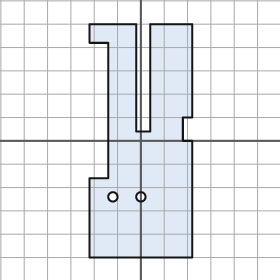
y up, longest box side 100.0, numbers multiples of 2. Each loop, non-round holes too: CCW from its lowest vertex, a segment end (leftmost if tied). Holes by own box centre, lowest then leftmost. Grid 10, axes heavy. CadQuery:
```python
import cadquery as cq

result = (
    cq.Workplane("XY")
    .moveTo(-22.0, -50.0)
    .lineTo(22.0, -50.0)
    .lineTo(22.0, 0.0)
    .lineTo(18.0, 0.0)
    .lineTo(18.0, 10.0)
    .lineTo(22.0, 10.0)
    .lineTo(22.0, 50.0)
    .lineTo(4.0, 50.0)
    .lineTo(4.0, 4.0)
    .lineTo(-2.0, 4.0)
    .lineTo(-2.0, 50.0)
    .lineTo(-22.0, 50.0)
    .lineTo(-22.0, 42.0)
    .lineTo(-14.0, 42.0)
    .lineTo(-14.0, -16.0)
    .lineTo(-22.0, -16.0)
    .close()
    .moveTo(-12.0, -24.0)
    .circle(2.0)
    .moveTo(0.0, -24.0)
    .circle(2.0)
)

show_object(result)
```